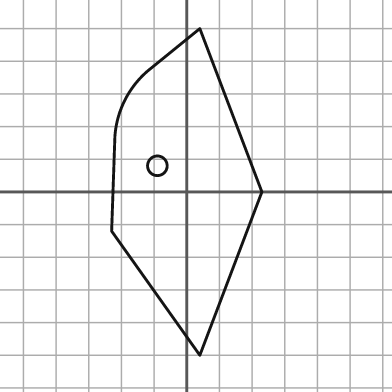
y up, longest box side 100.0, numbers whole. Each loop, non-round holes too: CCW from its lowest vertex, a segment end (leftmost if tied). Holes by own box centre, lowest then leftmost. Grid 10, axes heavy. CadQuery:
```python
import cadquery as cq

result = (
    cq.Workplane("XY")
    .moveTo(4.0, -50.0)
    .lineTo(23.0, 0.0)
    .lineTo(4.0, 50.0)
    .lineTo(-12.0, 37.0)
    .threePointArc((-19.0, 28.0), (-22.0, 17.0))
    .lineTo(-23.0, -12.0)
    .close()
    .moveTo(-9.0, 8.0)
    .circle(3.0)
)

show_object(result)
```